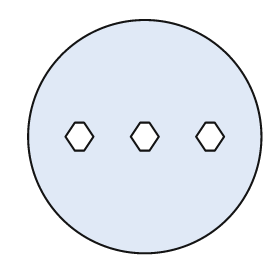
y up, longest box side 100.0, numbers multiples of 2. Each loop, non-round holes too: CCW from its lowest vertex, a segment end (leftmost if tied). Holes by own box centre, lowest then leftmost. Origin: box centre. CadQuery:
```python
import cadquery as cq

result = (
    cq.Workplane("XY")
    .moveTo(0.0, 0.0)
    .circle(50.0)
    .moveTo(-30.0, -6.0)
    .lineTo(-26.0, -6.0)
    .lineTo(-22.0, 0.0)
    .lineTo(-26.0, 6.0)
    .lineTo(-30.0, 6.0)
    .lineTo(-34.0, 0.0)
    .close()
    .moveTo(-2.0, -6.0)
    .lineTo(2.0, -6.0)
    .lineTo(6.0, 0.0)
    .lineTo(2.0, 6.0)
    .lineTo(-2.0, 6.0)
    .lineTo(-6.0, 0.0)
    .close()
    .moveTo(26.0, -6.0)
    .lineTo(30.0, -6.0)
    .lineTo(34.0, 0.0)
    .lineTo(30.0, 6.0)
    .lineTo(26.0, 6.0)
    .lineTo(22.0, 0.0)
    .close()
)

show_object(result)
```